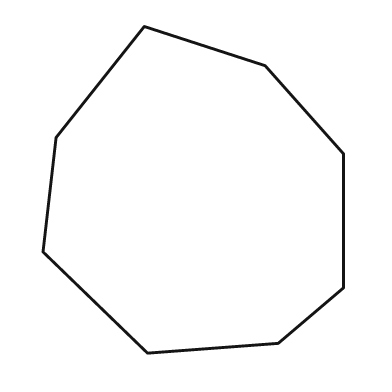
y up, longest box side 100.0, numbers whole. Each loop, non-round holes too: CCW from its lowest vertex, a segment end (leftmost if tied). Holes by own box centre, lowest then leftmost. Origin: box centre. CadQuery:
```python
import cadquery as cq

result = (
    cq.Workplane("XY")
    .moveTo(-14.0, -50.0)
    .lineTo(26.0, -47.0)
    .lineTo(46.0, -30.0)
    .lineTo(46.0, 11.0)
    .lineTo(22.0, 38.0)
    .lineTo(-15.0, 50.0)
    .lineTo(-42.0, 16.0)
    .lineTo(-46.0, -19.0)
    .close()
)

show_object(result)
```